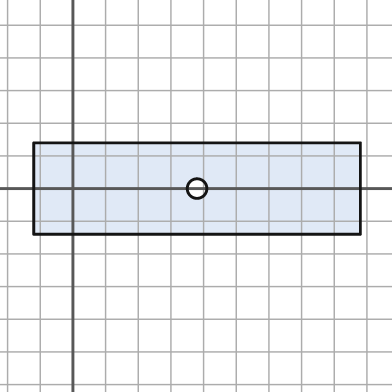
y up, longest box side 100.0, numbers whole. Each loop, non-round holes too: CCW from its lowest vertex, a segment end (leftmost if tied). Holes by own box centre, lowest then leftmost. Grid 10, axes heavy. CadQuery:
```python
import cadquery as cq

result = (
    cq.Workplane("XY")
    .moveTo(-12.0, -14.0)
    .lineTo(88.0, -14.0)
    .lineTo(88.0, 14.0)
    .lineTo(-12.0, 14.0)
    .close()
    .moveTo(38.0, 0.0)
    .circle(3.0)
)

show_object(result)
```